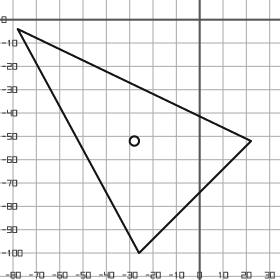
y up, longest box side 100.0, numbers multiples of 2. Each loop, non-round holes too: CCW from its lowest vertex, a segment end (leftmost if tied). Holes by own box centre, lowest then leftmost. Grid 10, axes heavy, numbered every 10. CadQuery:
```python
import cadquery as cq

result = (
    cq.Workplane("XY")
    .moveTo(-26.0, -100.0)
    .lineTo(22.0, -52.0)
    .lineTo(-78.0, -4.0)
    .close()
    .moveTo(-28.0, -52.0)
    .circle(2.0)
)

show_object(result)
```